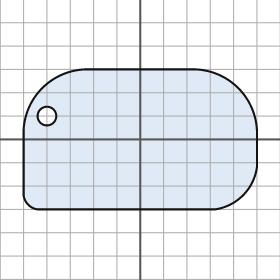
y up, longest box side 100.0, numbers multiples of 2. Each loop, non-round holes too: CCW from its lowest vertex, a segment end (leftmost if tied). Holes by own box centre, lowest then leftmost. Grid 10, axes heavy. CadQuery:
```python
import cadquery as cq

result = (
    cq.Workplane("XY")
    .moveTo(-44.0, -30.0)
    .lineTo(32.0, -30.0)
    .threePointArc((44.0, -24.0), (50.0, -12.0))
    .lineTo(50.0, 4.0)
    .threePointArc((42.0, 22.0), (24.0, 30.0))
    .lineTo(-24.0, 30.0)
    .threePointArc((-42.0, 22.0), (-50.0, 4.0))
    .lineTo(-50.0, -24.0)
    .threePointArc((-48.0, -28.0), (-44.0, -30.0))
    .close()
    .moveTo(-40.0, 10.0)
    .circle(4.0)
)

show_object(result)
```